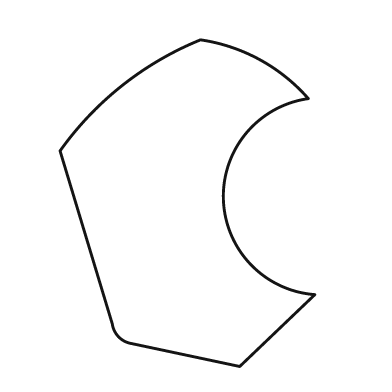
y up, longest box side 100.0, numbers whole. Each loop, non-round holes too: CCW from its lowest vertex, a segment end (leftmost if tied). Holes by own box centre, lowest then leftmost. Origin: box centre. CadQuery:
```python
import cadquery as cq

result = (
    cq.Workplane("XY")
    .moveTo(16.0, -50.0)
    .lineTo(39.0, -28.0)
    .threePointArc((11.0, 1.0), (37.0, 32.0))
    .threePointArc((22.0, 44.0), (4.0, 50.0))
    .threePointArc((-20.0, 36.0), (-39.0, 16.0))
    .lineTo(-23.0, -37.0)
    .threePointArc((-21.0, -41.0), (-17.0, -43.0))
    .close()
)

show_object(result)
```